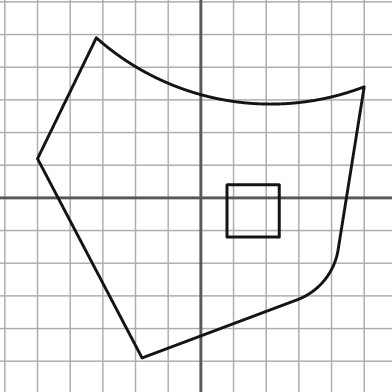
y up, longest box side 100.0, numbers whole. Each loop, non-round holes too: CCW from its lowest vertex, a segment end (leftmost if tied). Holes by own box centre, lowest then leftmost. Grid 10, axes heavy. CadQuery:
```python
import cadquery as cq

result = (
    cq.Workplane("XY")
    .moveTo(-18.0, -49.0)
    .lineTo(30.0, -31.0)
    .threePointArc((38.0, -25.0), (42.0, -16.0))
    .lineTo(50.0, 34.0)
    .threePointArc((7.0, 30.0), (-32.0, 49.0))
    .lineTo(-50.0, 12.0)
    .close()
    .moveTo(8.0, -12.0)
    .lineTo(24.0, -12.0)
    .lineTo(24.0, 4.0)
    .lineTo(8.0, 4.0)
    .close()
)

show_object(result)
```